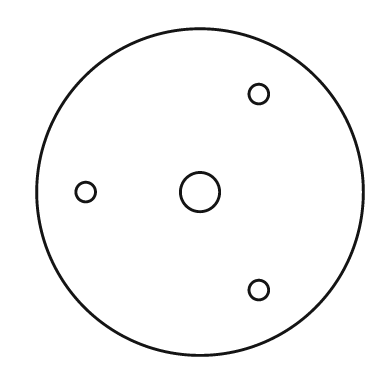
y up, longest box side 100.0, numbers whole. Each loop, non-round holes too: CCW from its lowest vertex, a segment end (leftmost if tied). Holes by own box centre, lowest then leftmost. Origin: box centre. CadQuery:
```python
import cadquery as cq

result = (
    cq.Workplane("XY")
    .moveTo(0.0, 0.0)
    .circle(50.0)
    .moveTo(18.0, -30.0)
    .circle(3.0)
    .moveTo(-35.0, 0.0)
    .circle(3.0)
    .moveTo(0.0, 0.0)
    .circle(6.0)
    .moveTo(18.0, 30.0)
    .circle(3.0)
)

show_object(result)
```